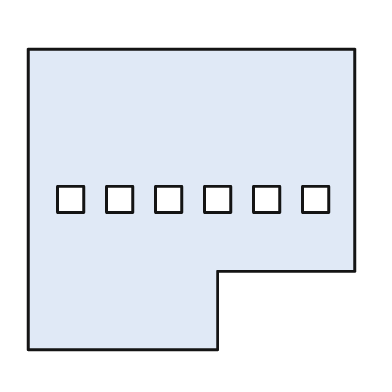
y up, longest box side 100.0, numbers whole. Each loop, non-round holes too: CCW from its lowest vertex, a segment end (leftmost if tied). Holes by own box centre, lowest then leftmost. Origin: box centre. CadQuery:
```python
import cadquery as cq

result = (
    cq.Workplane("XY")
    .moveTo(-50.0, -46.0)
    .lineTo(8.0, -46.0)
    .lineTo(8.0, -22.0)
    .lineTo(50.0, -22.0)
    .lineTo(50.0, 46.0)
    .lineTo(-50.0, 46.0)
    .close()
    .moveTo(-41.0, -4.0)
    .lineTo(-33.0, -4.0)
    .lineTo(-33.0, 4.0)
    .lineTo(-41.0, 4.0)
    .close()
    .moveTo(-26.0, -4.0)
    .lineTo(-18.0, -4.0)
    .lineTo(-18.0, 4.0)
    .lineTo(-26.0, 4.0)
    .close()
    .moveTo(-11.0, -4.0)
    .lineTo(-3.0, -4.0)
    .lineTo(-3.0, 4.0)
    .lineTo(-11.0, 4.0)
    .close()
    .moveTo(4.0, -4.0)
    .lineTo(12.0, -4.0)
    .lineTo(12.0, 4.0)
    .lineTo(4.0, 4.0)
    .close()
    .moveTo(19.0, -4.0)
    .lineTo(27.0, -4.0)
    .lineTo(27.0, 4.0)
    .lineTo(19.0, 4.0)
    .close()
    .moveTo(34.0, -4.0)
    .lineTo(42.0, -4.0)
    .lineTo(42.0, 4.0)
    .lineTo(34.0, 4.0)
    .close()
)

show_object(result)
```